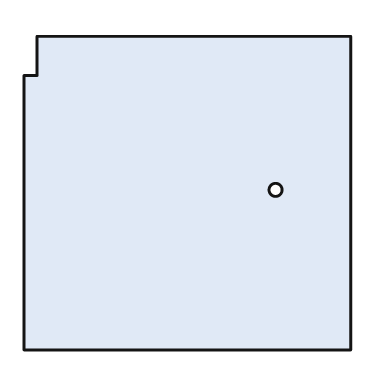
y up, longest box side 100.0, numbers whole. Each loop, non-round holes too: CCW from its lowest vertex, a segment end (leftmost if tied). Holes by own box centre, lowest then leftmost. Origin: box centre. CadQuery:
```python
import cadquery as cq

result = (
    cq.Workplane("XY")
    .moveTo(-50.0, -48.0)
    .lineTo(50.0, -48.0)
    .lineTo(50.0, 48.0)
    .lineTo(-46.0, 48.0)
    .lineTo(-46.0, 36.0)
    .lineTo(-50.0, 36.0)
    .close()
    .moveTo(27.0, 1.0)
    .circle(2.0)
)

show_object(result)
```